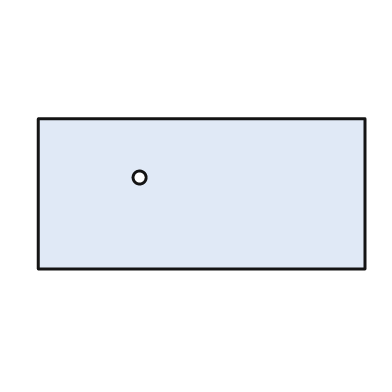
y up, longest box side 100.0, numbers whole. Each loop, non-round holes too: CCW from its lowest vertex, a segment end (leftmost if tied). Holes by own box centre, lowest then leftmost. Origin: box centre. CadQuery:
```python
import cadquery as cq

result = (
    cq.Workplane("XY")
    .moveTo(-50.0, -23.0)
    .lineTo(50.0, -23.0)
    .lineTo(50.0, 23.0)
    .lineTo(-50.0, 23.0)
    .close()
    .moveTo(-19.0, 5.0)
    .circle(2.0)
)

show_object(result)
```